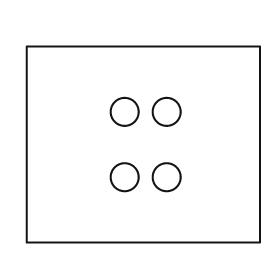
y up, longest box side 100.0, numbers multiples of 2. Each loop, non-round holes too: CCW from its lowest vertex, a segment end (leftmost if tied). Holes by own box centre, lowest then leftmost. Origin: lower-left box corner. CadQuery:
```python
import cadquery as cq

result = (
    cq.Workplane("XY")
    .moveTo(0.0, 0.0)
    .lineTo(100.0, 0.0)
    .lineTo(100.0, 84.0)
    .lineTo(0.0, 84.0)
    .close()
    .moveTo(42.0, 28.0)
    .circle(6.0)
    .moveTo(60.0, 28.0)
    .circle(6.0)
    .moveTo(42.0, 56.0)
    .circle(6.0)
    .moveTo(60.0, 56.0)
    .circle(6.0)
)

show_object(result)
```